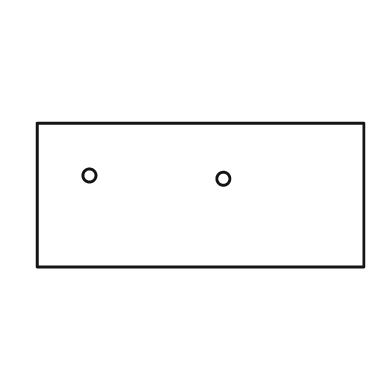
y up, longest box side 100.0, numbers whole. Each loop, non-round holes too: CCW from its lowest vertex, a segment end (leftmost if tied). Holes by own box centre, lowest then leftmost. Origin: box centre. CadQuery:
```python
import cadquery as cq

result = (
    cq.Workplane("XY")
    .moveTo(-50.0, -22.0)
    .lineTo(50.0, -22.0)
    .lineTo(50.0, 22.0)
    .lineTo(-50.0, 22.0)
    .close()
    .moveTo(7.0, 5.0)
    .circle(2.0)
    .moveTo(-34.0, 6.0)
    .circle(2.0)
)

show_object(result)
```